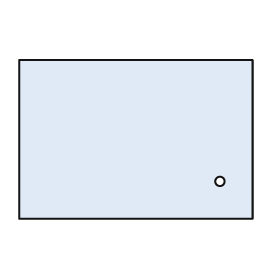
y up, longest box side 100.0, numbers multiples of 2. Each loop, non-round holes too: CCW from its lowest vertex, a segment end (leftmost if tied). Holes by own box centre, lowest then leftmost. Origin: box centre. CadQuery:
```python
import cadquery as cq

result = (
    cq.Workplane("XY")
    .moveTo(-50.0, -34.0)
    .lineTo(50.0, -34.0)
    .lineTo(50.0, 34.0)
    .lineTo(-50.0, 34.0)
    .close()
    .moveTo(36.0, -18.0)
    .circle(2.0)
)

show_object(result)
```